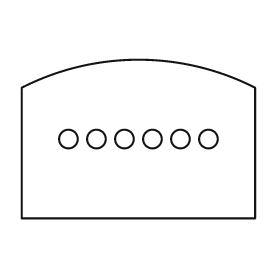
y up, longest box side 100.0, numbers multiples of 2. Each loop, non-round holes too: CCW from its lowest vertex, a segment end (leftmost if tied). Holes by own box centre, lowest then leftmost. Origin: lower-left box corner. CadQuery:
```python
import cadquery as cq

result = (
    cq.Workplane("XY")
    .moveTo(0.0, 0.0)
    .lineTo(100.0, 0.0)
    .lineTo(100.0, 56.0)
    .threePointArc((50.0, 68.0), (0.0, 56.0))
    .close()
    .moveTo(20.0, 34.0)
    .circle(4.0)
    .moveTo(32.0, 34.0)
    .circle(4.0)
    .moveTo(44.0, 34.0)
    .circle(4.0)
    .moveTo(56.0, 34.0)
    .circle(4.0)
    .moveTo(68.0, 34.0)
    .circle(4.0)
    .moveTo(80.0, 34.0)
    .circle(4.0)
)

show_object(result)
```